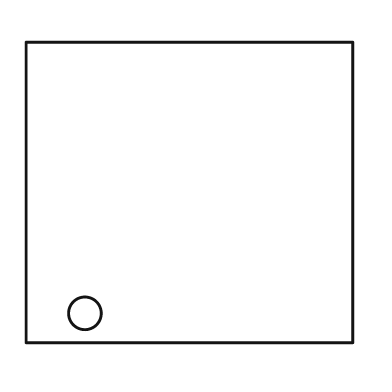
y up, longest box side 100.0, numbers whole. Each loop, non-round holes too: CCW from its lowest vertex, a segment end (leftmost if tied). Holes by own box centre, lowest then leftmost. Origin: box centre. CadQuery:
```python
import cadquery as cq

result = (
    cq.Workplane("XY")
    .moveTo(-50.0, -46.0)
    .lineTo(50.0, -46.0)
    .lineTo(50.0, 46.0)
    .lineTo(-50.0, 46.0)
    .close()
    .moveTo(-32.0, -37.0)
    .circle(5.0)
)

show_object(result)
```